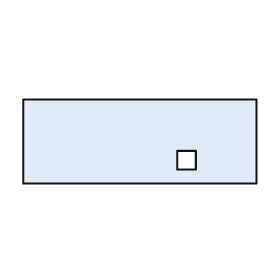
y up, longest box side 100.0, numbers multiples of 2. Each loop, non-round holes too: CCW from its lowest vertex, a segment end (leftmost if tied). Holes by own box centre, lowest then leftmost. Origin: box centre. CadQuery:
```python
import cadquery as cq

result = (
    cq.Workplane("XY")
    .moveTo(-50.0, -18.0)
    .lineTo(50.0, -18.0)
    .lineTo(50.0, 18.0)
    .lineTo(-50.0, 18.0)
    .close()
    .moveTo(16.0, -12.0)
    .lineTo(24.0, -12.0)
    .lineTo(24.0, -4.0)
    .lineTo(16.0, -4.0)
    .close()
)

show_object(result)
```